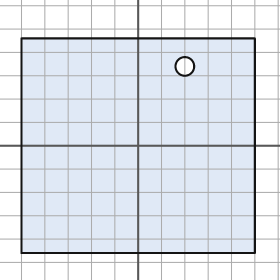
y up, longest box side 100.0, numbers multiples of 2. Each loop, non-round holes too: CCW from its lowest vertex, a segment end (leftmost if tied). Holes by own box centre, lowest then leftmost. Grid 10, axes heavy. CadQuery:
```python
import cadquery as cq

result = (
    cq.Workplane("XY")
    .moveTo(-50.0, -46.0)
    .lineTo(50.0, -46.0)
    .lineTo(50.0, 46.0)
    .lineTo(-50.0, 46.0)
    .close()
    .moveTo(20.0, 34.0)
    .circle(4.0)
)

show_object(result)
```